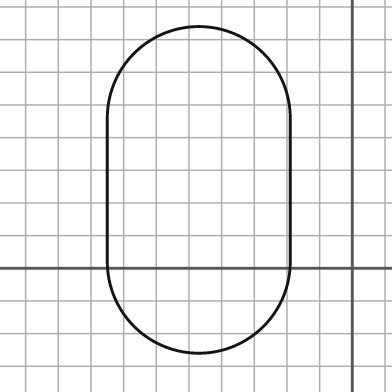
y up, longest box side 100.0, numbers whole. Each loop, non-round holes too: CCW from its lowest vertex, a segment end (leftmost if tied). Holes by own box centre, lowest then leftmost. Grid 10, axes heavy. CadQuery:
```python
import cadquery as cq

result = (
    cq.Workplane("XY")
    .moveTo(-75.0, 2.0)
    .threePointArc((-47.0, -26.0), (-19.0, 2.0))
    .lineTo(-19.0, 46.0)
    .threePointArc((-47.0, 74.0), (-75.0, 46.0))
    .close()
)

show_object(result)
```